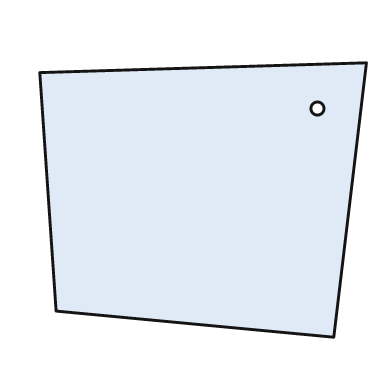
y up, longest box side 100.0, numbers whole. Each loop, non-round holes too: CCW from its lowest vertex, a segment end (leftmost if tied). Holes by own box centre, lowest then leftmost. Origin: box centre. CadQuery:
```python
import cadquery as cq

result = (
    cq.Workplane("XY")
    .moveTo(40.0, -42.0)
    .lineTo(50.0, 42.0)
    .lineTo(-50.0, 39.0)
    .lineTo(-45.0, -34.0)
    .close()
    .moveTo(35.0, 28.0)
    .circle(2.0)
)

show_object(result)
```